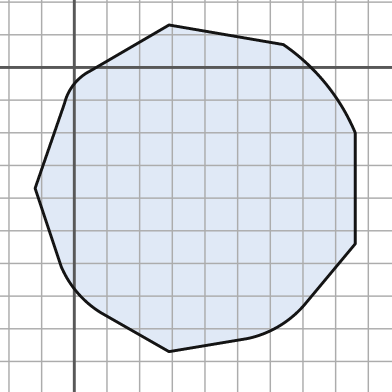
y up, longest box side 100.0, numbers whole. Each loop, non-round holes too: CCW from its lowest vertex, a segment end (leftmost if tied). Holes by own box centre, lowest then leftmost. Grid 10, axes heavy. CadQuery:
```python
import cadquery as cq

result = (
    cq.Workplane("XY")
    .moveTo(29.0, -87.0)
    .lineTo(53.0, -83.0)
    .threePointArc((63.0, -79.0), (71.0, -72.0))
    .lineTo(86.0, -54.0)
    .lineTo(86.0, -20.0)
    .threePointArc((77.0, -5.0), (64.0, 7.0))
    .lineTo(29.0, 13.0)
    .lineTo(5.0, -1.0)
    .threePointArc((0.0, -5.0), (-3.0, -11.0))
    .lineTo(-12.0, -37.0)
    .lineTo(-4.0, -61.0)
    .threePointArc((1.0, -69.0), (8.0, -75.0))
    .close()
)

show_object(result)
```